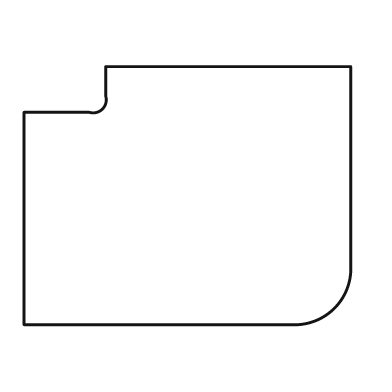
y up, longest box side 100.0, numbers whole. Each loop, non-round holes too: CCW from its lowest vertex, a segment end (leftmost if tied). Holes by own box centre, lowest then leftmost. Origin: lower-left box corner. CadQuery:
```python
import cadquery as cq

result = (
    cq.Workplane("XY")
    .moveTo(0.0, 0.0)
    .lineTo(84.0, 0.0)
    .threePointArc((95.0, 5.0), (100.0, 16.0))
    .lineTo(100.0, 79.0)
    .lineTo(25.0, 79.0)
    .lineTo(25.0, 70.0)
    .threePointArc((24.0, 66.0), (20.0, 65.0))
    .lineTo(0.0, 65.0)
    .close()
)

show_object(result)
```